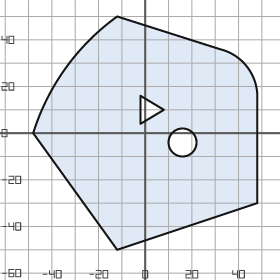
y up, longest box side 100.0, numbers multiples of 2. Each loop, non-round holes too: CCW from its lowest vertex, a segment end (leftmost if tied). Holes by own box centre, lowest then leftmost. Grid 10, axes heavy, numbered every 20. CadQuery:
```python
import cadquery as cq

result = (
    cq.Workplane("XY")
    .moveTo(-12.0, -50.0)
    .lineTo(48.0, -30.0)
    .lineTo(48.0, 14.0)
    .threePointArc((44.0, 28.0), (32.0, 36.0))
    .lineTo(-12.0, 50.0)
    .threePointArc((-34.0, 28.0), (-48.0, 0.0))
    .close()
    .moveTo(16.0, -4.0)
    .circle(6.0)
    .moveTo(-2.0, 4.0)
    .lineTo(8.0, 10.0)
    .lineTo(-2.0, 16.0)
    .close()
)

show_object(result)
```